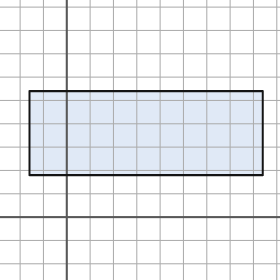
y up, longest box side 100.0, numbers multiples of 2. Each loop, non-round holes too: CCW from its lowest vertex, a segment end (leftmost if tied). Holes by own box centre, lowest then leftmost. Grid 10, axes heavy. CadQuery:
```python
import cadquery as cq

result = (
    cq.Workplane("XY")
    .moveTo(-16.0, 18.0)
    .lineTo(84.0, 18.0)
    .lineTo(84.0, 54.0)
    .lineTo(-16.0, 54.0)
    .close()
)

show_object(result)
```